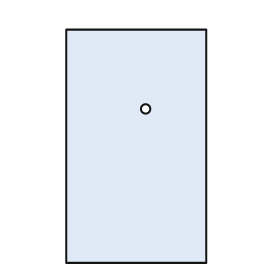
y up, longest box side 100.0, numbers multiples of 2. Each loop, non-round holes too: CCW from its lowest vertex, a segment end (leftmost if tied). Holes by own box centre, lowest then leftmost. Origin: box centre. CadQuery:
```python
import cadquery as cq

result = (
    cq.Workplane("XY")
    .moveTo(-30.0, -50.0)
    .lineTo(30.0, -50.0)
    .lineTo(30.0, 50.0)
    .lineTo(-30.0, 50.0)
    .close()
    .moveTo(4.0, 16.0)
    .circle(2.0)
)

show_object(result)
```